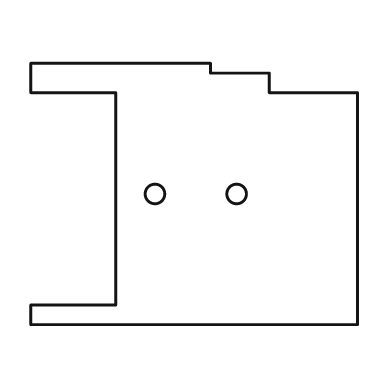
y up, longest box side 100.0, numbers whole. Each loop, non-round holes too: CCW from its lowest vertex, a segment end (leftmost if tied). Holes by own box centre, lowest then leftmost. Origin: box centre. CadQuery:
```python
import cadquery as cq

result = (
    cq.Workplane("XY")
    .moveTo(-50.0, -40.0)
    .lineTo(50.0, -40.0)
    .lineTo(50.0, 31.0)
    .lineTo(23.0, 31.0)
    .lineTo(23.0, 37.0)
    .lineTo(5.0, 37.0)
    .lineTo(5.0, 40.0)
    .lineTo(-50.0, 40.0)
    .lineTo(-50.0, 31.0)
    .lineTo(-24.0, 31.0)
    .lineTo(-24.0, -34.0)
    .lineTo(-50.0, -34.0)
    .close()
    .moveTo(-12.0, 0.0)
    .circle(3.0)
    .moveTo(13.0, 0.0)
    .circle(3.0)
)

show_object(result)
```